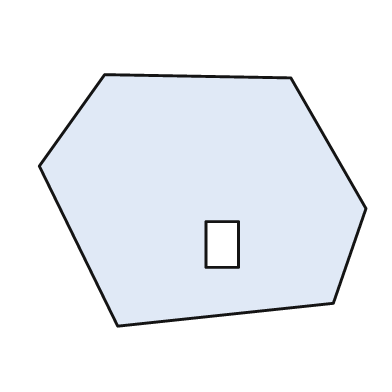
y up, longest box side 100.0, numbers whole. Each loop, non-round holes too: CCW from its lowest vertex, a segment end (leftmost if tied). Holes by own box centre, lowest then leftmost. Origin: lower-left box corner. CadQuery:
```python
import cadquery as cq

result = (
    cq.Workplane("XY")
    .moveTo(24.0, 0.0)
    .lineTo(90.0, 7.0)
    .lineTo(100.0, 36.0)
    .lineTo(77.0, 76.0)
    .lineTo(20.0, 77.0)
    .lineTo(0.0, 49.0)
    .close()
    .moveTo(51.0, 18.0)
    .lineTo(61.0, 18.0)
    .lineTo(61.0, 32.0)
    .lineTo(51.0, 32.0)
    .close()
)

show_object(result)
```